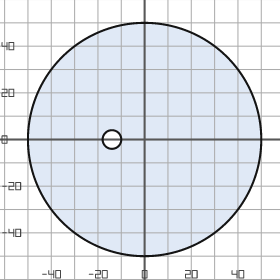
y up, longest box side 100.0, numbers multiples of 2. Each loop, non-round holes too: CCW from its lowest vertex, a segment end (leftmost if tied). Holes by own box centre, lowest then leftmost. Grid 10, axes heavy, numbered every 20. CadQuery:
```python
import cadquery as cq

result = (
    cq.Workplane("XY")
    .moveTo(0.0, 0.0)
    .circle(50.0)
    .moveTo(-14.0, 0.0)
    .circle(4.0)
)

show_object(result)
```